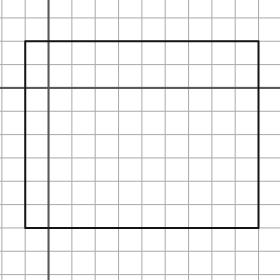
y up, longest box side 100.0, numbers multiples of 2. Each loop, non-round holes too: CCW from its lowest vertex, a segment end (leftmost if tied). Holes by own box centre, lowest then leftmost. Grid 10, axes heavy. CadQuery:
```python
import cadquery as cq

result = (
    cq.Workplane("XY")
    .moveTo(-10.0, -60.0)
    .lineTo(90.0, -60.0)
    .lineTo(90.0, 20.0)
    .lineTo(-10.0, 20.0)
    .close()
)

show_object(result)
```